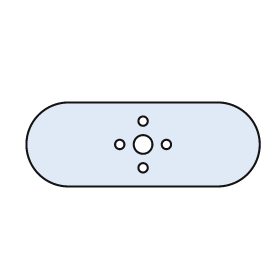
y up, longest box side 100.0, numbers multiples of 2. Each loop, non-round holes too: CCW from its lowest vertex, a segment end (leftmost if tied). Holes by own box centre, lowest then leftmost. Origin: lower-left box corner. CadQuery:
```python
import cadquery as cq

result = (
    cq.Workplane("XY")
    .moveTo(18.0, 0.0)
    .lineTo(82.0, 0.0)
    .threePointArc((100.0, 18.0), (82.0, 36.0))
    .lineTo(18.0, 36.0)
    .threePointArc((0.0, 18.0), (18.0, 0.0))
    .close()
    .moveTo(50.0, 8.0)
    .circle(2.0)
    .moveTo(40.0, 18.0)
    .circle(2.0)
    .moveTo(50.0, 18.0)
    .circle(4.0)
    .moveTo(60.0, 18.0)
    .circle(2.0)
    .moveTo(50.0, 28.0)
    .circle(2.0)
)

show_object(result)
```